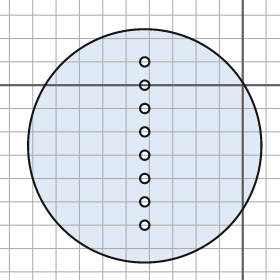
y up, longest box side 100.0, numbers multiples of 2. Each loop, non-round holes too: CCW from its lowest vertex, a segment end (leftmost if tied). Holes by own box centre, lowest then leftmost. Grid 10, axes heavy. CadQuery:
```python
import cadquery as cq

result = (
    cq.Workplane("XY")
    .moveTo(-42.0, -26.0)
    .circle(50.0)
    .moveTo(-42.0, -60.0)
    .circle(2.0)
    .moveTo(-42.0, -50.0)
    .circle(2.0)
    .moveTo(-42.0, -40.0)
    .circle(2.0)
    .moveTo(-42.0, -30.0)
    .circle(2.0)
    .moveTo(-42.0, -20.0)
    .circle(2.0)
    .moveTo(-42.0, -10.0)
    .circle(2.0)
    .moveTo(-42.0, 0.0)
    .circle(2.0)
    .moveTo(-42.0, 10.0)
    .circle(2.0)
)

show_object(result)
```